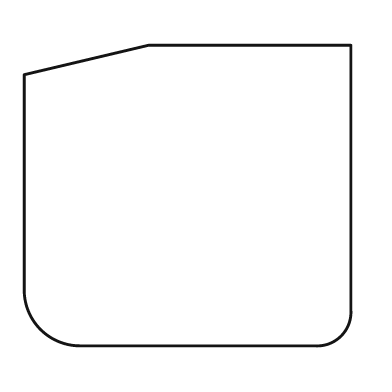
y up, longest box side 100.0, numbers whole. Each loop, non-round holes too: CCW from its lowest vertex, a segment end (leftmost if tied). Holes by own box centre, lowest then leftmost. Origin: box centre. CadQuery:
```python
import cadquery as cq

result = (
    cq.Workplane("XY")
    .moveTo(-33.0, -46.0)
    .lineTo(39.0, -46.0)
    .threePointArc((47.0, -43.0), (50.0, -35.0))
    .lineTo(50.0, 46.0)
    .lineTo(-12.0, 46.0)
    .lineTo(-50.0, 37.0)
    .lineTo(-50.0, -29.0)
    .threePointArc((-45.0, -41.0), (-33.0, -46.0))
    .close()
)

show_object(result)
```